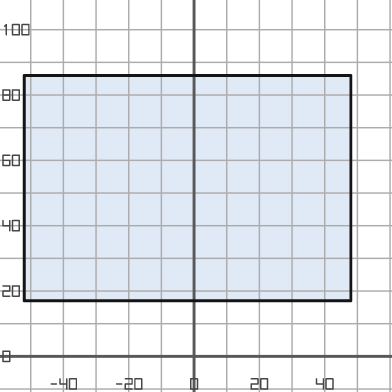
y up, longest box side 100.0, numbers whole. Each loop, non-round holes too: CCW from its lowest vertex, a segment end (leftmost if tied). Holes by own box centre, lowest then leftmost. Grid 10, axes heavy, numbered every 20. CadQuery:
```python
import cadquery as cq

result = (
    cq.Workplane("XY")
    .moveTo(-52.0, 17.0)
    .lineTo(48.0, 17.0)
    .lineTo(48.0, 86.0)
    .lineTo(-52.0, 86.0)
    .close()
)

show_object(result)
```